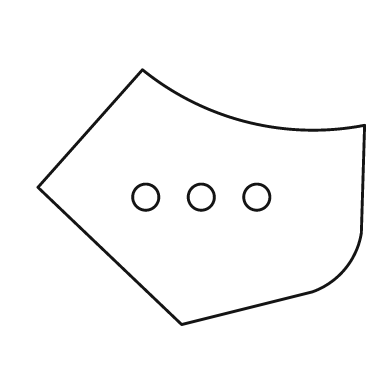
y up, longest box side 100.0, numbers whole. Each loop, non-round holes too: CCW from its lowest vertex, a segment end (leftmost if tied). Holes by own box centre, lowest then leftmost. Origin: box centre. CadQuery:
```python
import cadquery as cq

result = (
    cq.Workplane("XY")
    .moveTo(-6.0, -39.0)
    .lineTo(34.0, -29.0)
    .threePointArc((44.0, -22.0), (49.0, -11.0))
    .lineTo(50.0, 22.0)
    .threePointArc((14.0, 23.0), (-18.0, 39.0))
    .lineTo(-50.0, 3.0)
    .close()
    .moveTo(-17.0, 0.0)
    .circle(4.0)
    .moveTo(0.0, 0.0)
    .circle(4.0)
    .moveTo(17.0, 0.0)
    .circle(4.0)
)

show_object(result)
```